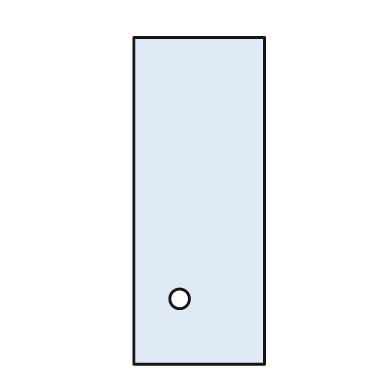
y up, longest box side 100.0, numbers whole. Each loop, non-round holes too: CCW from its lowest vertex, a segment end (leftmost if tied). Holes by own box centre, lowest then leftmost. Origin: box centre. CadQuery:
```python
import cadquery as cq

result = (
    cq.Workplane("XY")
    .moveTo(-20.0, -50.0)
    .lineTo(20.0, -50.0)
    .lineTo(20.0, 50.0)
    .lineTo(-20.0, 50.0)
    .close()
    .moveTo(-6.0, -30.0)
    .circle(3.0)
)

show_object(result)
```